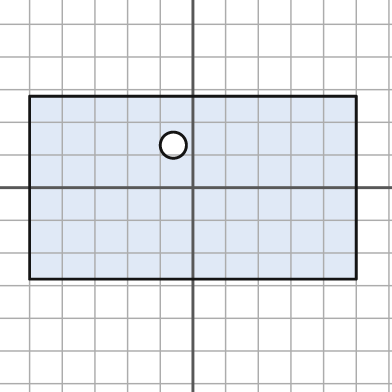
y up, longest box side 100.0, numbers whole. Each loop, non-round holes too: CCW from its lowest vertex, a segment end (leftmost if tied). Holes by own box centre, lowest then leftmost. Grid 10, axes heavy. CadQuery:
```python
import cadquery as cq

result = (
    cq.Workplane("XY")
    .moveTo(-50.0, -28.0)
    .lineTo(50.0, -28.0)
    .lineTo(50.0, 28.0)
    .lineTo(-50.0, 28.0)
    .close()
    .moveTo(-6.0, 13.0)
    .circle(4.0)
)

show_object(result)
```